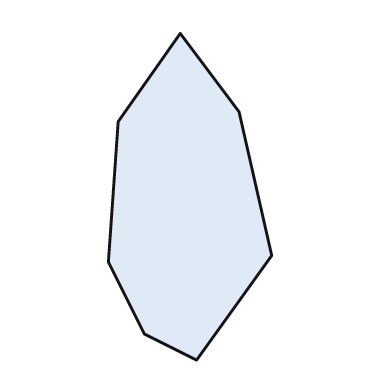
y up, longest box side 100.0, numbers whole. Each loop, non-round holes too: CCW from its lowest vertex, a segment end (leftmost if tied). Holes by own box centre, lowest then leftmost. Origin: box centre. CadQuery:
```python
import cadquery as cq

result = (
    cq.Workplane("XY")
    .moveTo(2.0, -50.0)
    .lineTo(25.0, -18.0)
    .lineTo(15.0, 26.0)
    .lineTo(-3.0, 50.0)
    .lineTo(-22.0, 23.0)
    .lineTo(-25.0, -20.0)
    .lineTo(-14.0, -42.0)
    .close()
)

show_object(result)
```